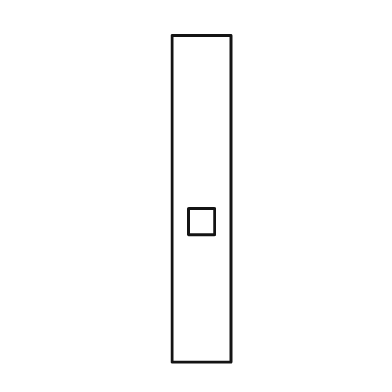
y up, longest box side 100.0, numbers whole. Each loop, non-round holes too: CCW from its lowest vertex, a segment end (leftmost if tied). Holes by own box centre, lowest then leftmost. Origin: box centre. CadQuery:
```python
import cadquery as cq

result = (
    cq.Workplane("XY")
    .moveTo(-9.0, -50.0)
    .lineTo(9.0, -50.0)
    .lineTo(9.0, 50.0)
    .lineTo(-9.0, 50.0)
    .close()
    .moveTo(-4.0, -11.0)
    .lineTo(4.0, -11.0)
    .lineTo(4.0, -3.0)
    .lineTo(-4.0, -3.0)
    .close()
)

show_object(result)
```